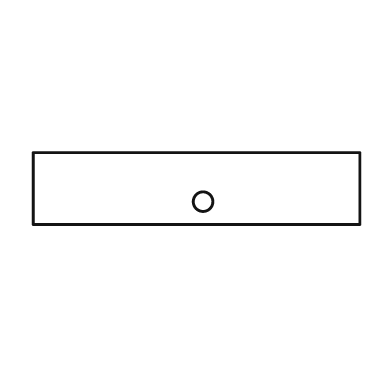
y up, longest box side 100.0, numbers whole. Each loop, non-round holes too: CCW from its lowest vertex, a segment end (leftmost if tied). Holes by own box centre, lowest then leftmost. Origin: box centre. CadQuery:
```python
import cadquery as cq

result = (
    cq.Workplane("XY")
    .moveTo(-50.0, -11.0)
    .lineTo(50.0, -11.0)
    .lineTo(50.0, 11.0)
    .lineTo(-50.0, 11.0)
    .close()
    .moveTo(2.0, -4.0)
    .circle(3.0)
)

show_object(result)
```